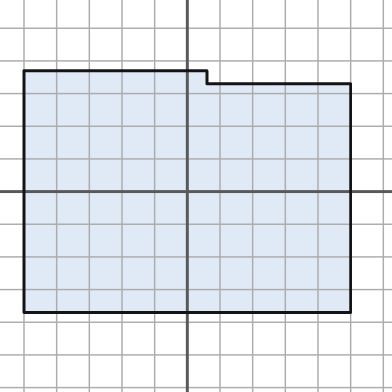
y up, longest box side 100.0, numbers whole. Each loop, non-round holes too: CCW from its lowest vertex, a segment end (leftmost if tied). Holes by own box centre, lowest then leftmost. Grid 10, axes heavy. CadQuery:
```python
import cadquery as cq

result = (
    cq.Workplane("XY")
    .moveTo(-50.0, -37.0)
    .lineTo(50.0, -37.0)
    .lineTo(50.0, 33.0)
    .lineTo(6.0, 33.0)
    .lineTo(6.0, 37.0)
    .lineTo(-50.0, 37.0)
    .close()
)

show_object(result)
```